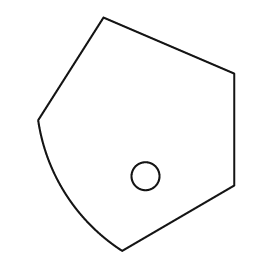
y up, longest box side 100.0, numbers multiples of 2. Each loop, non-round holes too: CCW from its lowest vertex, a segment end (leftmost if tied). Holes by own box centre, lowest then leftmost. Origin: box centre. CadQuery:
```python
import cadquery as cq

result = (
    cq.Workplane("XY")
    .moveTo(-6.0, -50.0)
    .lineTo(42.0, -22.0)
    .lineTo(42.0, 26.0)
    .lineTo(-14.0, 50.0)
    .lineTo(-42.0, 6.0)
    .threePointArc((-30.0, -26.0), (-6.0, -50.0))
    .close()
    .moveTo(4.0, -18.0)
    .circle(6.0)
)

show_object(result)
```